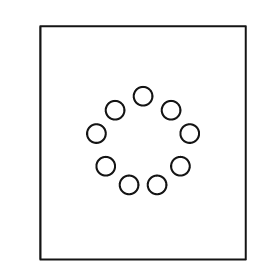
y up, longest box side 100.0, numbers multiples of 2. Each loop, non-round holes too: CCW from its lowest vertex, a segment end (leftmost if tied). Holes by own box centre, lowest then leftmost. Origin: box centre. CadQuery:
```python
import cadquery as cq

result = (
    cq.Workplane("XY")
    .moveTo(-44.0, -50.0)
    .lineTo(44.0, -50.0)
    .lineTo(44.0, 50.0)
    .lineTo(-44.0, 50.0)
    .close()
    .moveTo(-6.0, -18.0)
    .circle(4.0)
    .moveTo(6.0, -18.0)
    .circle(4.0)
    .moveTo(-16.0, -10.0)
    .circle(4.0)
    .moveTo(16.0, -10.0)
    .circle(4.0)
    .moveTo(-20.0, 4.0)
    .circle(4.0)
    .moveTo(20.0, 4.0)
    .circle(4.0)
    .moveTo(-12.0, 14.0)
    .circle(4.0)
    .moveTo(12.0, 14.0)
    .circle(4.0)
    .moveTo(0.0, 20.0)
    .circle(4.0)
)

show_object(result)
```